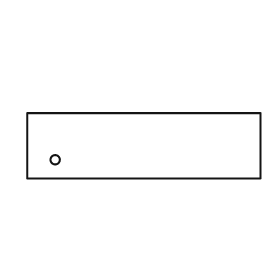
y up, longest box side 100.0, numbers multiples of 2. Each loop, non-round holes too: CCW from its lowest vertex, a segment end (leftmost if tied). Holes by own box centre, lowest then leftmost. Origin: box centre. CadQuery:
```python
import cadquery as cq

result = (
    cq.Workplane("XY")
    .moveTo(-50.0, -14.0)
    .lineTo(50.0, -14.0)
    .lineTo(50.0, 14.0)
    .lineTo(-50.0, 14.0)
    .close()
    .moveTo(-38.0, -6.0)
    .circle(2.0)
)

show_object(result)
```